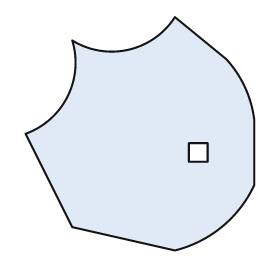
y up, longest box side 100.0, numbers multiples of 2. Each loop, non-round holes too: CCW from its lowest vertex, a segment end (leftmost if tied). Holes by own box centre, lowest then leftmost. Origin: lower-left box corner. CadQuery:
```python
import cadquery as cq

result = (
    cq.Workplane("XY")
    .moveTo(64.0, 0.0)
    .threePointArc((84.0, 10.0), (98.0, 28.0))
    .lineTo(98.0, 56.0)
    .threePointArc((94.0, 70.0), (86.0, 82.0))
    .lineTo(64.0, 100.0)
    .threePointArc((44.0, 86.0), (20.0, 90.0))
    .threePointArc((18.0, 66.0), (0.0, 50.0))
    .lineTo(20.0, 10.0)
    .close()
    .moveTo(70.0, 38.0)
    .lineTo(78.0, 38.0)
    .lineTo(78.0, 46.0)
    .lineTo(70.0, 46.0)
    .close()
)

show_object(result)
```